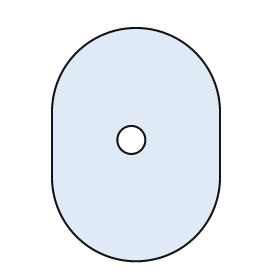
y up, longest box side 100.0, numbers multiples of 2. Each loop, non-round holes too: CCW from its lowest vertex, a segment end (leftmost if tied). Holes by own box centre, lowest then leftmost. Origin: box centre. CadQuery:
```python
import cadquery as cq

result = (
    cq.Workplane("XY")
    .moveTo(-36.0, -14.0)
    .threePointArc((0.0, -50.0), (36.0, -14.0))
    .lineTo(36.0, 14.0)
    .threePointArc((0.0, 50.0), (-36.0, 14.0))
    .close()
    .moveTo(-2.0, 2.0)
    .circle(6.0)
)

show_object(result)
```